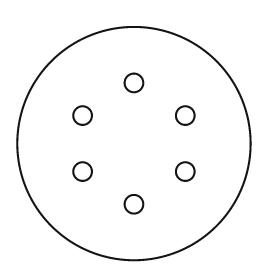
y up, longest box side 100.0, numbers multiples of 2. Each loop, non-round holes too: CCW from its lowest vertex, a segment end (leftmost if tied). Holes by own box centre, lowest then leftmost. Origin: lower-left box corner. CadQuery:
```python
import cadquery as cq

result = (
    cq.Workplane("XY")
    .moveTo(50.0, 50.0)
    .circle(50.0)
    .moveTo(50.0, 24.0)
    .circle(4.0)
    .moveTo(28.0, 38.0)
    .circle(4.0)
    .moveTo(72.0, 38.0)
    .circle(4.0)
    .moveTo(28.0, 62.0)
    .circle(4.0)
    .moveTo(72.0, 62.0)
    .circle(4.0)
    .moveTo(50.0, 76.0)
    .circle(4.0)
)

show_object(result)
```